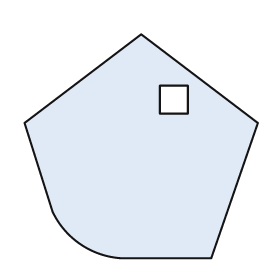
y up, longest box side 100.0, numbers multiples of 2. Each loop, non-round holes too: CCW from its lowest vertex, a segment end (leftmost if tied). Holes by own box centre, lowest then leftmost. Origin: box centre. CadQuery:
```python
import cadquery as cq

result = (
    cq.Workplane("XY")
    .moveTo(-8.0, -48.0)
    .lineTo(30.0, -48.0)
    .lineTo(50.0, 10.0)
    .lineTo(0.0, 48.0)
    .lineTo(-50.0, 10.0)
    .lineTo(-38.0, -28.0)
    .threePointArc((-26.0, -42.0), (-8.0, -48.0))
    .close()
    .moveTo(8.0, 14.0)
    .lineTo(20.0, 14.0)
    .lineTo(20.0, 26.0)
    .lineTo(8.0, 26.0)
    .close()
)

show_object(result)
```